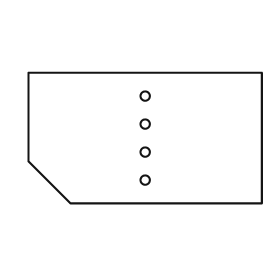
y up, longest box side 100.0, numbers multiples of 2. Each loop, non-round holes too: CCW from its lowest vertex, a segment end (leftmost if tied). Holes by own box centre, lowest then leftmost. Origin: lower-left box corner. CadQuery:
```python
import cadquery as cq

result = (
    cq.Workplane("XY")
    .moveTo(18.0, 0.0)
    .lineTo(100.0, 0.0)
    .lineTo(100.0, 56.0)
    .lineTo(0.0, 56.0)
    .lineTo(0.0, 18.0)
    .close()
    .moveTo(50.0, 10.0)
    .circle(2.0)
    .moveTo(50.0, 22.0)
    .circle(2.0)
    .moveTo(50.0, 34.0)
    .circle(2.0)
    .moveTo(50.0, 46.0)
    .circle(2.0)
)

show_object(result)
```